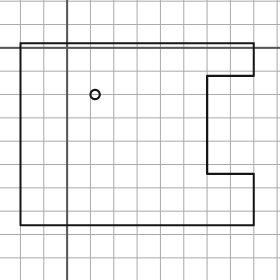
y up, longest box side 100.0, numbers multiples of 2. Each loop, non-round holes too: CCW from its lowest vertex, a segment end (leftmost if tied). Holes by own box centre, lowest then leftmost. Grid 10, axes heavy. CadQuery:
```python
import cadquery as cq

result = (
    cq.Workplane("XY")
    .moveTo(-20.0, -76.0)
    .lineTo(80.0, -76.0)
    .lineTo(80.0, -54.0)
    .lineTo(60.0, -54.0)
    .lineTo(60.0, -12.0)
    .lineTo(80.0, -12.0)
    .lineTo(80.0, 2.0)
    .lineTo(-20.0, 2.0)
    .close()
    .moveTo(12.0, -20.0)
    .circle(2.0)
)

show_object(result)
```